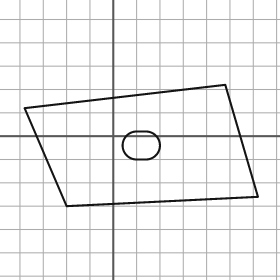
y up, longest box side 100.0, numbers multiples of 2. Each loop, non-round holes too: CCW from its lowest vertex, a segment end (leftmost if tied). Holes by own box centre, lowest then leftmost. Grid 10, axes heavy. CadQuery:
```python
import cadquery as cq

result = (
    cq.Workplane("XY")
    .moveTo(-20.0, -30.0)
    .lineTo(62.0, -26.0)
    .lineTo(48.0, 22.0)
    .lineTo(-38.0, 12.0)
    .close()
    .moveTo(10.0, -10.0)
    .lineTo(14.0, -10.0)
    .threePointArc((20.0, -4.0), (14.0, 2.0))
    .lineTo(10.0, 2.0)
    .threePointArc((4.0, -4.0), (10.0, -10.0))
    .close()
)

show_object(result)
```